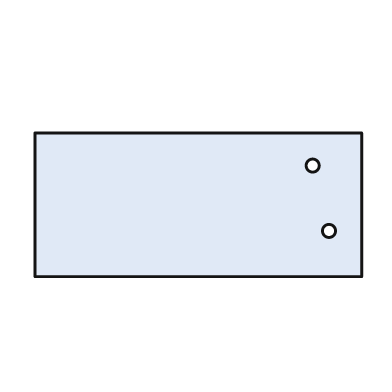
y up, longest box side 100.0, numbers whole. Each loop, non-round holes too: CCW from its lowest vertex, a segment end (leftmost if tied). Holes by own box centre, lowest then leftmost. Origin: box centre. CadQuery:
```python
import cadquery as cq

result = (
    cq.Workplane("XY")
    .moveTo(-50.0, -22.0)
    .lineTo(50.0, -22.0)
    .lineTo(50.0, 22.0)
    .lineTo(-50.0, 22.0)
    .close()
    .moveTo(40.0, -8.0)
    .circle(2.0)
    .moveTo(35.0, 12.0)
    .circle(2.0)
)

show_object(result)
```